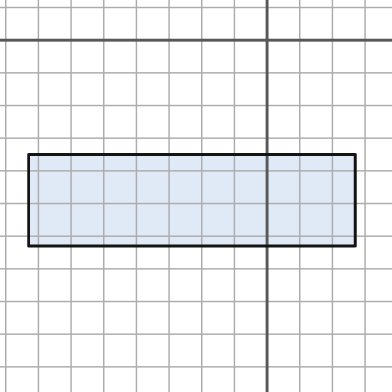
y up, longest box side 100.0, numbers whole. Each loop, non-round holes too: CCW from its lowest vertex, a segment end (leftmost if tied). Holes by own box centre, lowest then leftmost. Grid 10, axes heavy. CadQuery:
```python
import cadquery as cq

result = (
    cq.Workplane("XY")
    .moveTo(-73.0, -63.0)
    .lineTo(27.0, -63.0)
    .lineTo(27.0, -35.0)
    .lineTo(-73.0, -35.0)
    .close()
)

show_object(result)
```